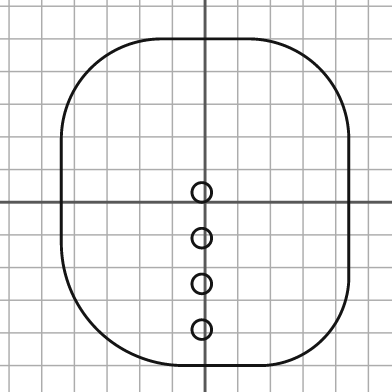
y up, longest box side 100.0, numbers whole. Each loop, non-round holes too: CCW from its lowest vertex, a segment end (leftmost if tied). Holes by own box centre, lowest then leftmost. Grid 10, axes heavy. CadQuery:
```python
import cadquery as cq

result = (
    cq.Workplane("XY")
    .moveTo(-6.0, -50.0)
    .lineTo(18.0, -50.0)
    .threePointArc((36.0, -42.0), (44.0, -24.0))
    .lineTo(44.0, 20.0)
    .threePointArc((35.0, 41.0), (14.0, 50.0))
    .lineTo(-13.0, 50.0)
    .threePointArc((-35.0, 41.0), (-44.0, 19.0))
    .lineTo(-44.0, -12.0)
    .threePointArc((-33.0, -39.0), (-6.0, -50.0))
    .close()
    .moveTo(-1.0, -39.0)
    .circle(3.0)
    .moveTo(-1.0, -25.0)
    .circle(3.0)
    .moveTo(-1.0, -11.0)
    .circle(3.0)
    .moveTo(-1.0, 3.0)
    .circle(3.0)
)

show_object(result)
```